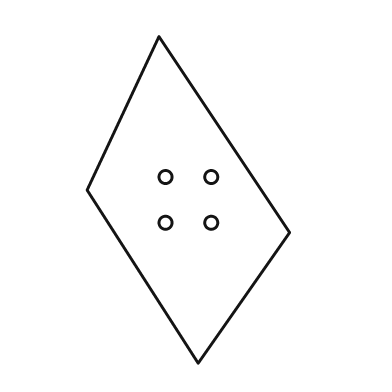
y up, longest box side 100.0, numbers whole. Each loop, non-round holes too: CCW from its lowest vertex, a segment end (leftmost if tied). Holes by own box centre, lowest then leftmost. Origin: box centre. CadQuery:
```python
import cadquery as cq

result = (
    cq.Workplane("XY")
    .moveTo(3.0, -50.0)
    .lineTo(31.0, -10.0)
    .lineTo(-9.0, 50.0)
    .lineTo(-31.0, 3.0)
    .close()
    .moveTo(-7.0, -7.0)
    .circle(2.0)
    .moveTo(7.0, -7.0)
    .circle(2.0)
    .moveTo(-7.0, 7.0)
    .circle(2.0)
    .moveTo(7.0, 7.0)
    .circle(2.0)
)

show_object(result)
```